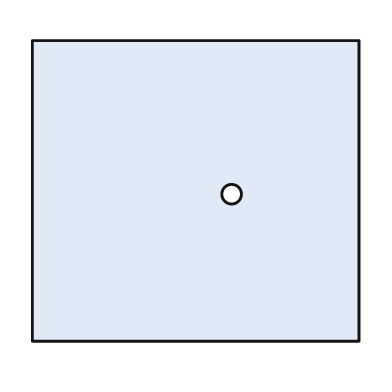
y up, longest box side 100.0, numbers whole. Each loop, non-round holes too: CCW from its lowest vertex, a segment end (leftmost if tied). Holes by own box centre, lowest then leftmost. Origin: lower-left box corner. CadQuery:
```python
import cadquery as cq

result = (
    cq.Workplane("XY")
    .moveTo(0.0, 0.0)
    .lineTo(100.0, 0.0)
    .lineTo(100.0, 92.0)
    .lineTo(0.0, 92.0)
    .close()
    .moveTo(61.0, 45.0)
    .circle(3.0)
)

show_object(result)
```